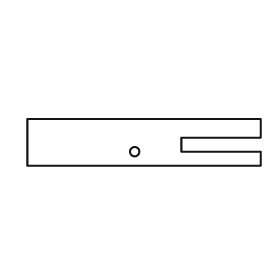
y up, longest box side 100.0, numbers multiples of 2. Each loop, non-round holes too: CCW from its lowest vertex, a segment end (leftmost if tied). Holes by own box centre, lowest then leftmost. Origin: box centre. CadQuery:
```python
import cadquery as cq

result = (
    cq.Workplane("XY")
    .moveTo(-50.0, -10.0)
    .lineTo(50.0, -10.0)
    .lineTo(50.0, -4.0)
    .lineTo(16.0, -4.0)
    .lineTo(16.0, 2.0)
    .lineTo(50.0, 2.0)
    .lineTo(50.0, 10.0)
    .lineTo(-50.0, 10.0)
    .close()
    .moveTo(-4.0, -4.0)
    .circle(2.0)
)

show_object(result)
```